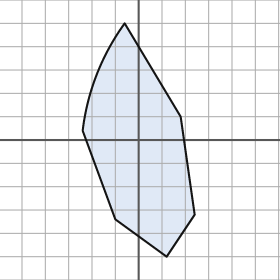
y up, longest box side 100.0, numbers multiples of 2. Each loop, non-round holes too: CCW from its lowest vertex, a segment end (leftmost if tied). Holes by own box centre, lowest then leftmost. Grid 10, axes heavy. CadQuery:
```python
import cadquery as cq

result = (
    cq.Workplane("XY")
    .moveTo(12.0, -50.0)
    .lineTo(24.0, -32.0)
    .lineTo(18.0, 10.0)
    .lineTo(-6.0, 50.0)
    .threePointArc((-18.0, 28.0), (-24.0, 4.0))
    .lineTo(-10.0, -34.0)
    .close()
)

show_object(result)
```